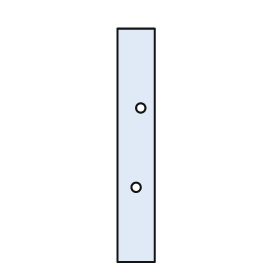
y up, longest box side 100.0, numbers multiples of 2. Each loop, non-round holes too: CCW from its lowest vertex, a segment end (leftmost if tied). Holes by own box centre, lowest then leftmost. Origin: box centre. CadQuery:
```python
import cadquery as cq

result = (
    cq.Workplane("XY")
    .moveTo(-8.0, -50.0)
    .lineTo(8.0, -50.0)
    .lineTo(8.0, 50.0)
    .lineTo(-8.0, 50.0)
    .close()
    .moveTo(0.0, -18.0)
    .circle(2.0)
    .moveTo(2.0, 16.0)
    .circle(2.0)
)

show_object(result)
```